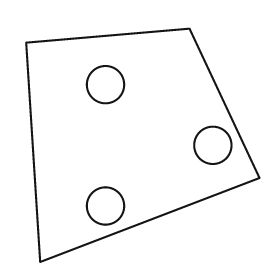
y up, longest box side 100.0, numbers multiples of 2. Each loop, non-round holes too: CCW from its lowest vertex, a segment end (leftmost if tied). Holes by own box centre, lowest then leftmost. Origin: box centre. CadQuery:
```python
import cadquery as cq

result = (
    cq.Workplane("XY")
    .moveTo(-44.0, -50.0)
    .lineTo(50.0, -14.0)
    .lineTo(20.0, 50.0)
    .lineTo(-50.0, 44.0)
    .close()
    .moveTo(-16.0, -26.0)
    .circle(8.0)
    .moveTo(30.0, 0.0)
    .circle(8.0)
    .moveTo(-16.0, 26.0)
    .circle(8.0)
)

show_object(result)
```